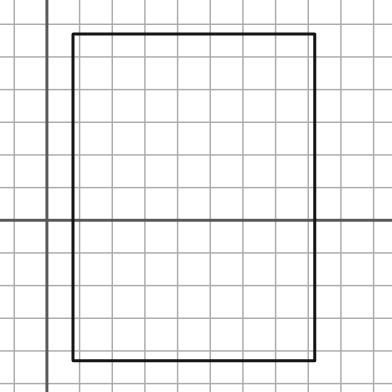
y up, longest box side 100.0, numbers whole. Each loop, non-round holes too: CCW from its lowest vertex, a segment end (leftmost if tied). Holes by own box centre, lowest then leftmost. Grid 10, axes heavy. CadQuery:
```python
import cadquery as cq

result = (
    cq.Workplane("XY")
    .moveTo(8.0, -43.0)
    .lineTo(82.0, -43.0)
    .lineTo(82.0, 57.0)
    .lineTo(8.0, 57.0)
    .close()
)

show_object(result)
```